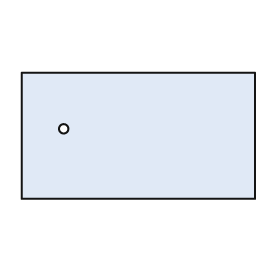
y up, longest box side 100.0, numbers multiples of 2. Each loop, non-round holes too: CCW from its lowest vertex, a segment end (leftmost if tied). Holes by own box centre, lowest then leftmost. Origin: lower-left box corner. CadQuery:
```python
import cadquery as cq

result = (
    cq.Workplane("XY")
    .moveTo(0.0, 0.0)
    .lineTo(100.0, 0.0)
    .lineTo(100.0, 54.0)
    .lineTo(0.0, 54.0)
    .close()
    .moveTo(18.0, 30.0)
    .circle(2.0)
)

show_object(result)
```